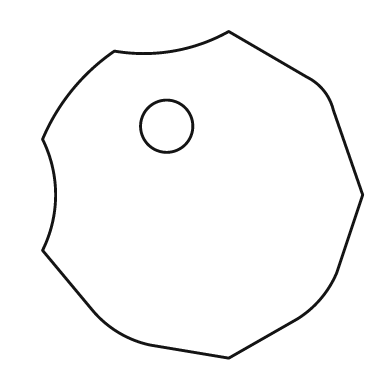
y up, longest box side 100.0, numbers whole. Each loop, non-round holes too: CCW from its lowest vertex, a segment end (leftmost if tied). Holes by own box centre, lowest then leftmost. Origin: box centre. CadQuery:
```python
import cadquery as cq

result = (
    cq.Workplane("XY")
    .moveTo(8.0, -50.0)
    .lineTo(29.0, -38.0)
    .threePointArc((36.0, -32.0), (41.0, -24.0))
    .lineTo(49.0, 0.0)
    .lineTo(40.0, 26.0)
    .threePointArc((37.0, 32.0), (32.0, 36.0))
    .lineTo(8.0, 50.0)
    .threePointArc((-9.0, 44.0), (-27.0, 44.0))
    .threePointArc((-40.0, 32.0), (-49.0, 17.0))
    .threePointArc((-45.0, 0.0), (-49.0, -17.0))
    .lineTo(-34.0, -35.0)
    .threePointArc((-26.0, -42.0), (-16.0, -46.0))
    .close()
    .moveTo(-11.0, 21.0)
    .circle(8.0)
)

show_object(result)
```